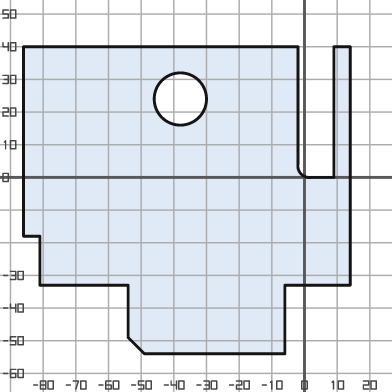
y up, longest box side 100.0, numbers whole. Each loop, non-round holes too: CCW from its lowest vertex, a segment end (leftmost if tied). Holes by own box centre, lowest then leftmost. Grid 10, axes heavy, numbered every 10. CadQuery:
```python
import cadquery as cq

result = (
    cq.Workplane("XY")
    .moveTo(-49.0, -54.0)
    .lineTo(-6.0, -54.0)
    .lineTo(-6.0, -33.0)
    .lineTo(14.0, -33.0)
    .lineTo(14.0, 40.0)
    .lineTo(9.0, 40.0)
    .lineTo(9.0, 0.0)
    .lineTo(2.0, 0.0)
    .threePointArc((-1.0, 1.0), (-2.0, 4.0))
    .lineTo(-2.0, 40.0)
    .lineTo(-86.0, 40.0)
    .lineTo(-86.0, -18.0)
    .lineTo(-81.0, -18.0)
    .lineTo(-81.0, -33.0)
    .lineTo(-54.0, -33.0)
    .lineTo(-54.0, -49.0)
    .close()
    .moveTo(-38.0, 24.0)
    .circle(8.0)
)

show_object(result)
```